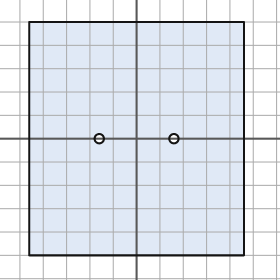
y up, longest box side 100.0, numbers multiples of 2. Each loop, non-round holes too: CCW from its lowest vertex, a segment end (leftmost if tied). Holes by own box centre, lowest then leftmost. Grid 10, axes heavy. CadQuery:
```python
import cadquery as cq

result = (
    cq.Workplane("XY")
    .moveTo(-46.0, -50.0)
    .lineTo(46.0, -50.0)
    .lineTo(46.0, 50.0)
    .lineTo(-46.0, 50.0)
    .close()
    .moveTo(-16.0, 0.0)
    .circle(2.0)
    .moveTo(16.0, 0.0)
    .circle(2.0)
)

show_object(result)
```